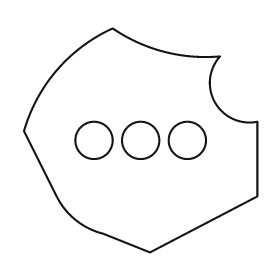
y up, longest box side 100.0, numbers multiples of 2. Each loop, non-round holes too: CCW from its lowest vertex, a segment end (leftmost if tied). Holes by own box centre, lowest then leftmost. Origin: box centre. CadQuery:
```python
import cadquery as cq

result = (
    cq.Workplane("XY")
    .moveTo(4.0, -48.0)
    .lineTo(50.0, -24.0)
    .lineTo(50.0, 8.0)
    .threePointArc((32.0, 16.0), (34.0, 36.0))
    .threePointArc((10.0, 38.0), (-12.0, 48.0))
    .threePointArc((-36.0, 30.0), (-50.0, 4.0))
    .lineTo(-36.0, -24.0)
    .threePointArc((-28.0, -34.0), (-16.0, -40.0))
    .close()
    .moveTo(-20.0, 0.0)
    .circle(8.0)
    .moveTo(0.0, 0.0)
    .circle(8.0)
    .moveTo(20.0, 0.0)
    .circle(8.0)
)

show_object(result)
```